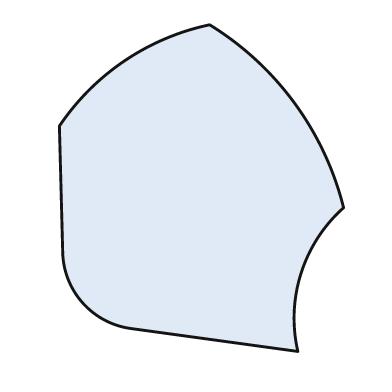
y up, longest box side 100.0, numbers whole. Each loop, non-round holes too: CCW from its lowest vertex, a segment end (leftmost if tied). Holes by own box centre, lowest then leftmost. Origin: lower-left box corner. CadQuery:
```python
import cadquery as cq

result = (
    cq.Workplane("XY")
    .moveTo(73.0, 0.0)
    .threePointArc((74.0, 24.0), (87.0, 44.0))
    .threePointArc((72.0, 76.0), (46.0, 100.0))
    .threePointArc((20.0, 89.0), (0.0, 69.0))
    .lineTo(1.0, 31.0)
    .threePointArc((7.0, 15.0), (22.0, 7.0))
    .close()
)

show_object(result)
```